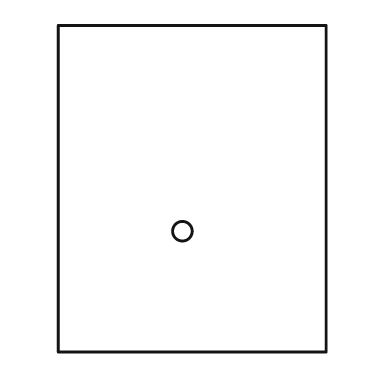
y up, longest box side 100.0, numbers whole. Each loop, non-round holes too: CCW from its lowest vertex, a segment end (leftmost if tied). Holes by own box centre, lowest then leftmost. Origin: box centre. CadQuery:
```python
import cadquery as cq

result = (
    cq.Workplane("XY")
    .moveTo(-41.0, -50.0)
    .lineTo(41.0, -50.0)
    .lineTo(41.0, 50.0)
    .lineTo(-41.0, 50.0)
    .close()
    .moveTo(-3.0, -13.0)
    .circle(3.0)
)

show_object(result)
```